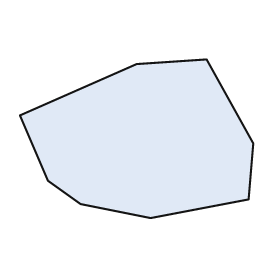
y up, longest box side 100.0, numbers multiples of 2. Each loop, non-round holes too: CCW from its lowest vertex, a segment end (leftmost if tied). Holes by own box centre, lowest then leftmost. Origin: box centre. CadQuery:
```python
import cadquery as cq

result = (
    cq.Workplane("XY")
    .moveTo(6.0, -34.0)
    .lineTo(48.0, -26.0)
    .lineTo(50.0, -2.0)
    .lineTo(30.0, 34.0)
    .lineTo(0.0, 32.0)
    .lineTo(-50.0, 10.0)
    .lineTo(-38.0, -18.0)
    .lineTo(-24.0, -28.0)
    .close()
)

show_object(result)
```